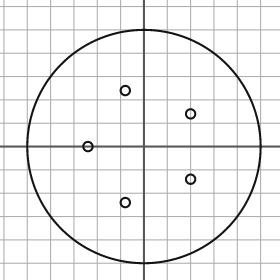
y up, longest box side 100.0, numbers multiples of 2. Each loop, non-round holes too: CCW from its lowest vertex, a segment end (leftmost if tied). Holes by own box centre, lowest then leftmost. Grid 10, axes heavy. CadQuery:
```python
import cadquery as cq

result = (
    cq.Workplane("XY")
    .moveTo(0.0, 0.0)
    .circle(50.0)
    .moveTo(-8.0, -24.0)
    .circle(2.0)
    .moveTo(20.0, -14.0)
    .circle(2.0)
    .moveTo(-24.0, 0.0)
    .circle(2.0)
    .moveTo(20.0, 14.0)
    .circle(2.0)
    .moveTo(-8.0, 24.0)
    .circle(2.0)
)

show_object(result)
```